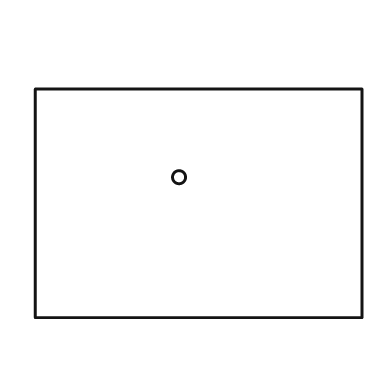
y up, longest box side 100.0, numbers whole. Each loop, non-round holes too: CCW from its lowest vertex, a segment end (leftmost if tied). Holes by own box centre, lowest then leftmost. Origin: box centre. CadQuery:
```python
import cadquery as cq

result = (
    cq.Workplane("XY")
    .moveTo(-50.0, -35.0)
    .lineTo(50.0, -35.0)
    .lineTo(50.0, 35.0)
    .lineTo(-50.0, 35.0)
    .close()
    .moveTo(-6.0, 8.0)
    .circle(2.0)
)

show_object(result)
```